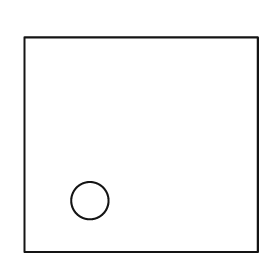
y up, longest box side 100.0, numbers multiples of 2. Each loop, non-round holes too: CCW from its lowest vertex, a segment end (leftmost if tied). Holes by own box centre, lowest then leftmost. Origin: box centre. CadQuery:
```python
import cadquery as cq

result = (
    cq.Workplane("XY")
    .moveTo(-50.0, -46.0)
    .lineTo(50.0, -46.0)
    .lineTo(50.0, 46.0)
    .lineTo(-50.0, 46.0)
    .close()
    .moveTo(-22.0, -24.0)
    .circle(8.0)
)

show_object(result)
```